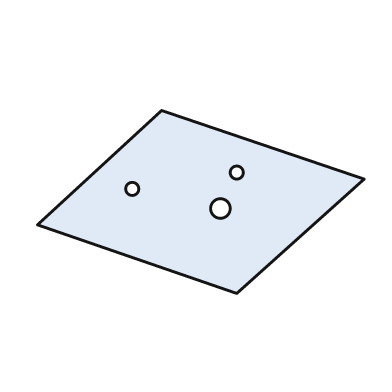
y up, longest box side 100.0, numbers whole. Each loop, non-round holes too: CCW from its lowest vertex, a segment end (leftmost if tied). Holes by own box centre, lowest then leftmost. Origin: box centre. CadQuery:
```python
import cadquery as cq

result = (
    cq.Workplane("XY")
    .moveTo(11.0, -28.0)
    .lineTo(50.0, 7.0)
    .lineTo(-12.0, 28.0)
    .lineTo(-50.0, -7.0)
    .close()
    .moveTo(6.0, -2.0)
    .circle(3.0)
    .moveTo(-21.0, 4.0)
    .circle(2.0)
    .moveTo(11.0, 9.0)
    .circle(2.0)
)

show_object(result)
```